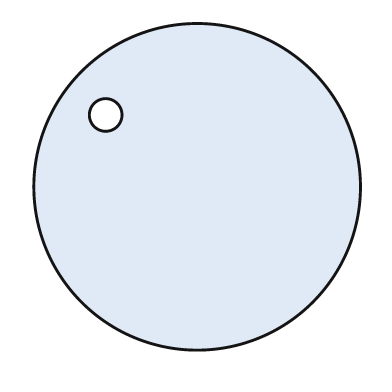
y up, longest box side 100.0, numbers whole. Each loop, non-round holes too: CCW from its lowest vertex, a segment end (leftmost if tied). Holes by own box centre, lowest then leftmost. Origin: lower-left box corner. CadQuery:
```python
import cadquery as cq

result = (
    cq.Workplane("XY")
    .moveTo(50.0, 50.0)
    .circle(50.0)
    .moveTo(22.0, 72.0)
    .circle(5.0)
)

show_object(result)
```